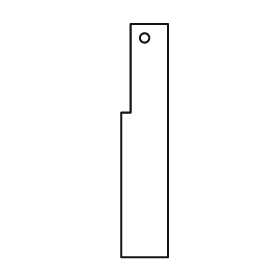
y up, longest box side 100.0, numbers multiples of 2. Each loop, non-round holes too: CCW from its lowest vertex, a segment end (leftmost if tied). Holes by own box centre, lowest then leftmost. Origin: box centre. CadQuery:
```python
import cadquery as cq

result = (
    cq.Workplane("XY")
    .moveTo(-10.0, -50.0)
    .lineTo(10.0, -50.0)
    .lineTo(10.0, 50.0)
    .lineTo(-6.0, 50.0)
    .lineTo(-6.0, 12.0)
    .lineTo(-10.0, 12.0)
    .close()
    .moveTo(0.0, 44.0)
    .circle(2.0)
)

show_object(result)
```